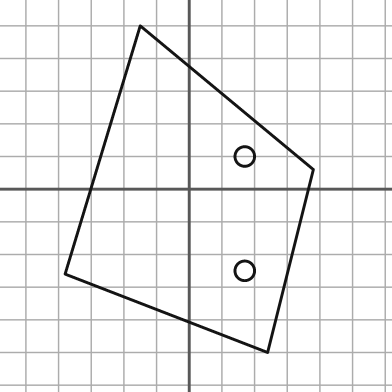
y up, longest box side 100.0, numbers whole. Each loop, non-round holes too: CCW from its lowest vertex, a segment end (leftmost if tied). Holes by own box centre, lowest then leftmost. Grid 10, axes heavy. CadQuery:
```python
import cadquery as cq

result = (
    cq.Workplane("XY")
    .moveTo(24.0, -50.0)
    .lineTo(38.0, 6.0)
    .lineTo(-15.0, 50.0)
    .lineTo(-38.0, -26.0)
    .close()
    .moveTo(17.0, -25.0)
    .circle(3.0)
    .moveTo(17.0, 10.0)
    .circle(3.0)
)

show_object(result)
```